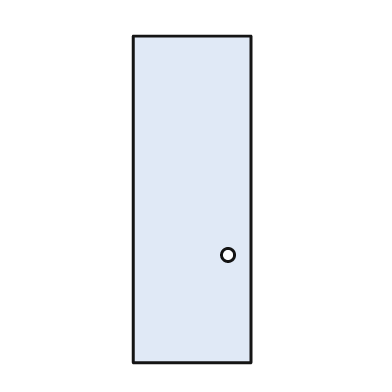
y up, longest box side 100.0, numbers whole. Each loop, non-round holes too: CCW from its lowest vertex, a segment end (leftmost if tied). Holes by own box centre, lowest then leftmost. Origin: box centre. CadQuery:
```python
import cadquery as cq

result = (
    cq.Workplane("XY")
    .moveTo(-18.0, -50.0)
    .lineTo(18.0, -50.0)
    .lineTo(18.0, 50.0)
    .lineTo(-18.0, 50.0)
    .close()
    .moveTo(11.0, -17.0)
    .circle(2.0)
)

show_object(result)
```